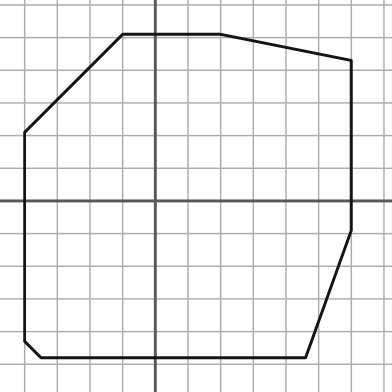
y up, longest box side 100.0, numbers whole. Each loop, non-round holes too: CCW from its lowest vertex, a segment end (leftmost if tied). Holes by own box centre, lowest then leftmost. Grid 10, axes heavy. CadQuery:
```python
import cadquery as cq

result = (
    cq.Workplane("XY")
    .moveTo(-35.0, -48.0)
    .lineTo(46.0, -48.0)
    .lineTo(60.0, -9.0)
    .lineTo(60.0, 43.0)
    .lineTo(20.0, 51.0)
    .lineTo(-10.0, 51.0)
    .lineTo(-40.0, 21.0)
    .lineTo(-40.0, -43.0)
    .close()
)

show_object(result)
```